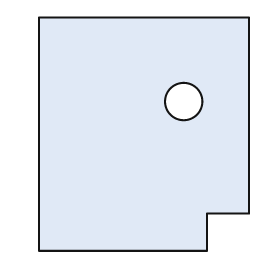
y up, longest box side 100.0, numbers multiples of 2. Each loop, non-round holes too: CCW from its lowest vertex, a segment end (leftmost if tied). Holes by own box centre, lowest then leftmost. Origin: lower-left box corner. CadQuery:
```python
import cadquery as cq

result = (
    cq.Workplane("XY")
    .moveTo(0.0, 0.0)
    .lineTo(72.0, 0.0)
    .lineTo(72.0, 16.0)
    .lineTo(90.0, 16.0)
    .lineTo(90.0, 100.0)
    .lineTo(0.0, 100.0)
    .close()
    .moveTo(62.0, 64.0)
    .circle(8.0)
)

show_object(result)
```